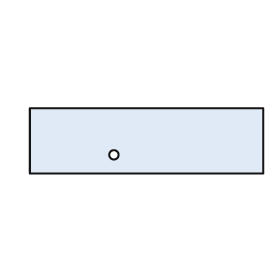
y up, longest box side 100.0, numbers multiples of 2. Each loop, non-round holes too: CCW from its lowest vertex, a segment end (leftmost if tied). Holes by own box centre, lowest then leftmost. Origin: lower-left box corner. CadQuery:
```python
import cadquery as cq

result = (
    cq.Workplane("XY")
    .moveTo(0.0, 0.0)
    .lineTo(100.0, 0.0)
    .lineTo(100.0, 28.0)
    .lineTo(0.0, 28.0)
    .close()
    .moveTo(36.0, 8.0)
    .circle(2.0)
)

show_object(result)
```